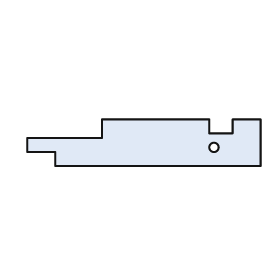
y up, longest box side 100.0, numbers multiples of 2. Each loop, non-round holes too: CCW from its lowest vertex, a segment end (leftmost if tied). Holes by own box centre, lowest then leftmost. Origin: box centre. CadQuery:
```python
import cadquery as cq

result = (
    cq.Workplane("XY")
    .moveTo(-38.0, -10.0)
    .lineTo(50.0, -10.0)
    .lineTo(50.0, 10.0)
    .lineTo(38.0, 10.0)
    .lineTo(38.0, 4.0)
    .lineTo(28.0, 4.0)
    .lineTo(28.0, 10.0)
    .lineTo(-18.0, 10.0)
    .lineTo(-18.0, 2.0)
    .lineTo(-50.0, 2.0)
    .lineTo(-50.0, -4.0)
    .lineTo(-38.0, -4.0)
    .close()
    .moveTo(30.0, -2.0)
    .circle(2.0)
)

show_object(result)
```